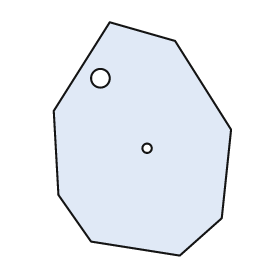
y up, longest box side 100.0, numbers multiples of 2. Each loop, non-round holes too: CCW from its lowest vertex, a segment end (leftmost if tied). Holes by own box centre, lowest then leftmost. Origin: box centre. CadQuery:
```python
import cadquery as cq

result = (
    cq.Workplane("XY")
    .moveTo(16.0, -50.0)
    .lineTo(34.0, -34.0)
    .lineTo(38.0, 4.0)
    .lineTo(14.0, 42.0)
    .lineTo(-14.0, 50.0)
    .lineTo(-38.0, 12.0)
    .lineTo(-36.0, -24.0)
    .lineTo(-22.0, -44.0)
    .close()
    .moveTo(2.0, -4.0)
    .circle(2.0)
    .moveTo(-18.0, 26.0)
    .circle(4.0)
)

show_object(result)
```